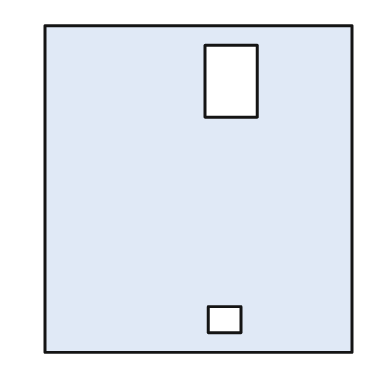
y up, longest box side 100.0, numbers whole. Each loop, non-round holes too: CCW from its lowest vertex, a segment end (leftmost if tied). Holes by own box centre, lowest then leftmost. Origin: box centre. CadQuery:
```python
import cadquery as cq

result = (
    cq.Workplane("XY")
    .moveTo(-47.0, -50.0)
    .lineTo(47.0, -50.0)
    .lineTo(47.0, 50.0)
    .lineTo(-47.0, 50.0)
    .close()
    .moveTo(3.0, -44.0)
    .lineTo(13.0, -44.0)
    .lineTo(13.0, -36.0)
    .lineTo(3.0, -36.0)
    .close()
    .moveTo(2.0, 22.0)
    .lineTo(18.0, 22.0)
    .lineTo(18.0, 44.0)
    .lineTo(2.0, 44.0)
    .close()
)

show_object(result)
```